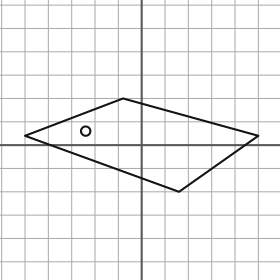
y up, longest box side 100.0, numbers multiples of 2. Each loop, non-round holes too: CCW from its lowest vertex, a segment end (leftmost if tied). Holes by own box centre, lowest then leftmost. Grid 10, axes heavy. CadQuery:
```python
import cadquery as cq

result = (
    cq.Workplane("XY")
    .moveTo(16.0, -20.0)
    .lineTo(50.0, 4.0)
    .lineTo(-8.0, 20.0)
    .lineTo(-50.0, 4.0)
    .close()
    .moveTo(-24.0, 6.0)
    .circle(2.0)
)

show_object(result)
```